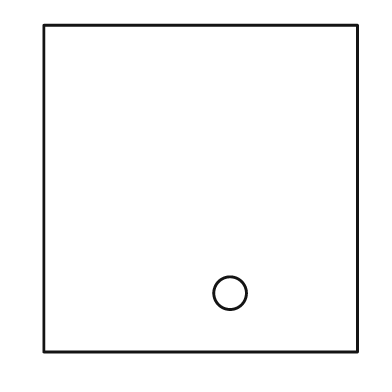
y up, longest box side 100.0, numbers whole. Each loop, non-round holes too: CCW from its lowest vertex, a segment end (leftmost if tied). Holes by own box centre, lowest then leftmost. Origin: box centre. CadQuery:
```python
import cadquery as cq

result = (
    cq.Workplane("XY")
    .moveTo(-48.0, -50.0)
    .lineTo(48.0, -50.0)
    .lineTo(48.0, 50.0)
    .lineTo(-48.0, 50.0)
    .close()
    .moveTo(9.0, -32.0)
    .circle(5.0)
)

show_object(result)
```